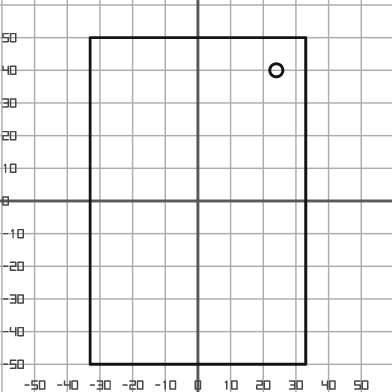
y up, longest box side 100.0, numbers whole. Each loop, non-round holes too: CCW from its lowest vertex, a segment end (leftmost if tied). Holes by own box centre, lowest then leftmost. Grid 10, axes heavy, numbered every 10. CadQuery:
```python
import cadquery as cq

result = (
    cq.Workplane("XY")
    .moveTo(-33.0, -50.0)
    .lineTo(33.0, -50.0)
    .lineTo(33.0, 50.0)
    .lineTo(-33.0, 50.0)
    .close()
    .moveTo(24.0, 40.0)
    .circle(2.0)
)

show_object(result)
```